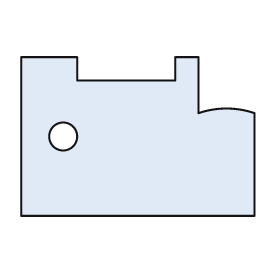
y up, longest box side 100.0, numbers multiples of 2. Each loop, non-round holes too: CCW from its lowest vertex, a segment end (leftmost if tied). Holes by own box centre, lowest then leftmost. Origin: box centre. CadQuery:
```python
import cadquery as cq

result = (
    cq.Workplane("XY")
    .moveTo(-50.0, -34.0)
    .lineTo(50.0, -34.0)
    .lineTo(50.0, 10.0)
    .threePointArc((38.0, 12.0), (26.0, 10.0))
    .lineTo(26.0, 34.0)
    .lineTo(16.0, 34.0)
    .lineTo(16.0, 24.0)
    .lineTo(-26.0, 24.0)
    .lineTo(-26.0, 34.0)
    .lineTo(-50.0, 34.0)
    .close()
    .moveTo(-32.0, 0.0)
    .circle(6.0)
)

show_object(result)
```